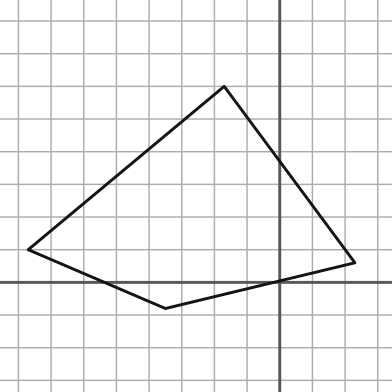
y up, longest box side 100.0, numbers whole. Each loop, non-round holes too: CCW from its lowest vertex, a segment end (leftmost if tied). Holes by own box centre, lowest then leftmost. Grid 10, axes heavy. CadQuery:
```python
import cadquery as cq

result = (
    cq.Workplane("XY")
    .moveTo(-35.0, -8.0)
    .lineTo(23.0, 6.0)
    .lineTo(-17.0, 60.0)
    .lineTo(-77.0, 10.0)
    .close()
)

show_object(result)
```